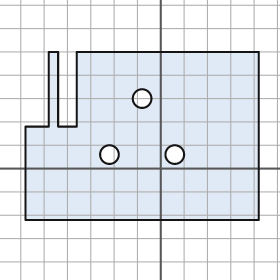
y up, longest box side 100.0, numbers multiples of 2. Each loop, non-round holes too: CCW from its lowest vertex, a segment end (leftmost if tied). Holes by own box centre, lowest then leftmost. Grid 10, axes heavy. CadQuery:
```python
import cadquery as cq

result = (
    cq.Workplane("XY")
    .moveTo(-58.0, -22.0)
    .lineTo(42.0, -22.0)
    .lineTo(42.0, 50.0)
    .lineTo(-36.0, 50.0)
    .lineTo(-36.0, 18.0)
    .lineTo(-44.0, 18.0)
    .lineTo(-44.0, 50.0)
    .lineTo(-48.0, 50.0)
    .lineTo(-48.0, 18.0)
    .lineTo(-58.0, 18.0)
    .close()
    .moveTo(-22.0, 6.0)
    .circle(4.0)
    .moveTo(6.0, 6.0)
    .circle(4.0)
    .moveTo(-8.0, 30.0)
    .circle(4.0)
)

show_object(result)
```